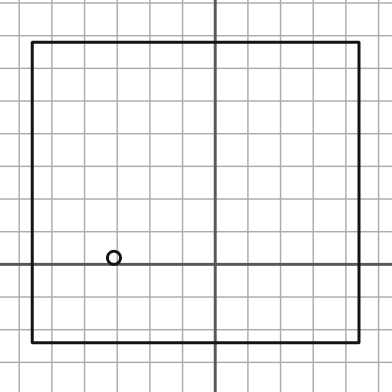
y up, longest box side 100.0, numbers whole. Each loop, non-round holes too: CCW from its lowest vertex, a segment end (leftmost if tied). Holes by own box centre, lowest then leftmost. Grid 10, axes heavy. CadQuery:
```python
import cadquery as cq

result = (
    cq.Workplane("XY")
    .moveTo(-56.0, -24.0)
    .lineTo(44.0, -24.0)
    .lineTo(44.0, 68.0)
    .lineTo(-56.0, 68.0)
    .close()
    .moveTo(-31.0, 2.0)
    .circle(2.0)
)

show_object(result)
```